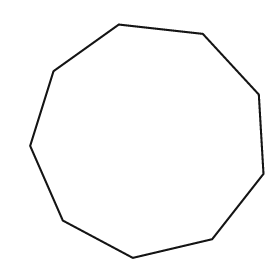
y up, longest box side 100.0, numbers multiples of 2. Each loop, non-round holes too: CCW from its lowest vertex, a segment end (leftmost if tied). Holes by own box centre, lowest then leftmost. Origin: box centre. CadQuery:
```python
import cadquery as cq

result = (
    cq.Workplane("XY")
    .moveTo(-6.0, -50.0)
    .lineTo(28.0, -42.0)
    .lineTo(50.0, -14.0)
    .lineTo(48.0, 20.0)
    .lineTo(24.0, 46.0)
    .lineTo(-12.0, 50.0)
    .lineTo(-40.0, 30.0)
    .lineTo(-50.0, -2.0)
    .lineTo(-36.0, -34.0)
    .close()
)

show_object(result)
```